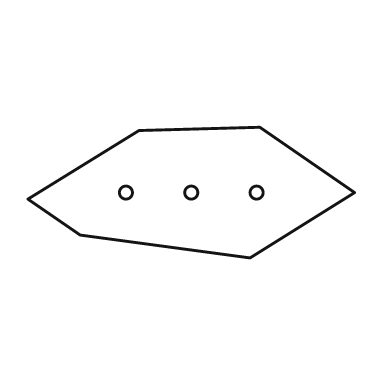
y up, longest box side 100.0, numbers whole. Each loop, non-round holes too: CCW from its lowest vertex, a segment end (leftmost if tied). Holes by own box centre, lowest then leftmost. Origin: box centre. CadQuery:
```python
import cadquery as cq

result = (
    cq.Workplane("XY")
    .moveTo(18.0, -20.0)
    .lineTo(50.0, 0.0)
    .lineTo(21.0, 20.0)
    .lineTo(-16.0, 19.0)
    .lineTo(-50.0, -2.0)
    .lineTo(-34.0, -13.0)
    .close()
    .moveTo(-20.0, 0.0)
    .circle(2.0)
    .moveTo(0.0, 0.0)
    .circle(2.0)
    .moveTo(20.0, 0.0)
    .circle(2.0)
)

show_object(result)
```